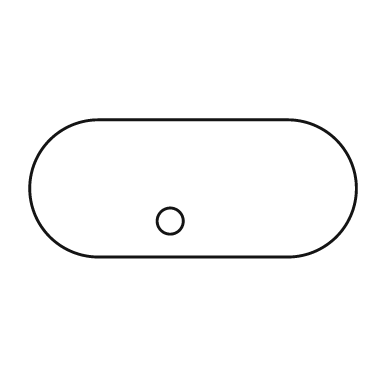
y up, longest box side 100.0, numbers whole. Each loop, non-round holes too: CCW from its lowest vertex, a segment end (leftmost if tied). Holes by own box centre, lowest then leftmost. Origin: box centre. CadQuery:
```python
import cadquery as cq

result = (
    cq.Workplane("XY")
    .moveTo(-29.0, -21.0)
    .lineTo(29.0, -21.0)
    .threePointArc((50.0, 0.0), (29.0, 21.0))
    .lineTo(-29.0, 21.0)
    .threePointArc((-50.0, 0.0), (-29.0, -21.0))
    .close()
    .moveTo(-7.0, -10.0)
    .circle(4.0)
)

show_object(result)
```